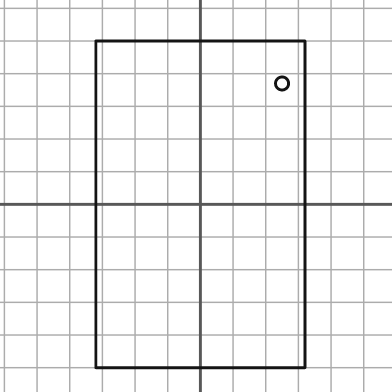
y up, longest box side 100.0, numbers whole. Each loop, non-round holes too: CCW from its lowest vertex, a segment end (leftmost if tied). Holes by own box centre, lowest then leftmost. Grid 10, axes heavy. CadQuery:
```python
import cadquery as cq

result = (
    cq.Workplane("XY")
    .moveTo(-32.0, -50.0)
    .lineTo(32.0, -50.0)
    .lineTo(32.0, 50.0)
    .lineTo(-32.0, 50.0)
    .close()
    .moveTo(25.0, 37.0)
    .circle(2.0)
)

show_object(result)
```